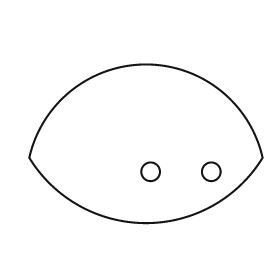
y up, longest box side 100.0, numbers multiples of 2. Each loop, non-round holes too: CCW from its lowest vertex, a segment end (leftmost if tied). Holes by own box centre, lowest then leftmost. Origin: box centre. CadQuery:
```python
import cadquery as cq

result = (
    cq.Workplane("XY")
    .moveTo(-50.0, -6.0)
    .threePointArc((0.0, -34.0), (50.0, -6.0))
    .threePointArc((0.0, 34.0), (-50.0, -6.0))
    .close()
    .moveTo(2.0, -12.0)
    .circle(4.0)
    .moveTo(28.0, -12.0)
    .circle(4.0)
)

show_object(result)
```